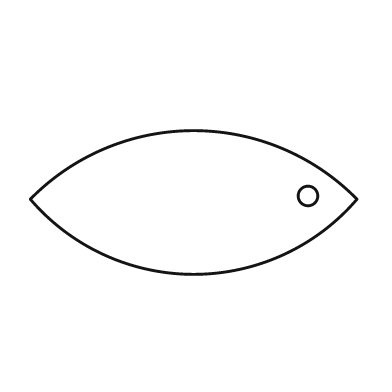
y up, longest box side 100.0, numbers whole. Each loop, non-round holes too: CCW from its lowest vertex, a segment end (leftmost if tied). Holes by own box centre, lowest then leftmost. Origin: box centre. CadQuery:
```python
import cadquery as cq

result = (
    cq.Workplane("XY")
    .moveTo(-50.0, 1.0)
    .threePointArc((0.0, -22.0), (50.0, 1.0))
    .threePointArc((0.0, 22.0), (-50.0, 1.0))
    .close()
    .moveTo(35.0, 2.0)
    .circle(3.0)
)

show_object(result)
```